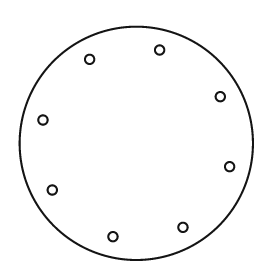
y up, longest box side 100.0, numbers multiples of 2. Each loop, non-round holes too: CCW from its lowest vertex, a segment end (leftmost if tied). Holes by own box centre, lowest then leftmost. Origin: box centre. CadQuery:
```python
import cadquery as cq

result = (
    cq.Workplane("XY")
    .moveTo(0.0, 0.0)
    .circle(50.0)
    .moveTo(-10.0, -40.0)
    .circle(2.0)
    .moveTo(20.0, -36.0)
    .circle(2.0)
    .moveTo(-36.0, -20.0)
    .circle(2.0)
    .moveTo(40.0, -10.0)
    .circle(2.0)
    .moveTo(-40.0, 10.0)
    .circle(2.0)
    .moveTo(36.0, 20.0)
    .circle(2.0)
    .moveTo(-20.0, 36.0)
    .circle(2.0)
    .moveTo(10.0, 40.0)
    .circle(2.0)
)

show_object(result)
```